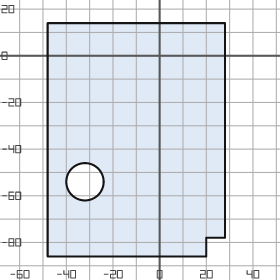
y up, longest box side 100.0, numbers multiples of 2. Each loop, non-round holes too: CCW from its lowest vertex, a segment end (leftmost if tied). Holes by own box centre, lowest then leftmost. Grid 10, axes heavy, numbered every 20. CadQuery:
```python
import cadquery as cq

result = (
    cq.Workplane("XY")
    .moveTo(-48.0, -86.0)
    .lineTo(20.0, -86.0)
    .lineTo(20.0, -78.0)
    .lineTo(28.0, -78.0)
    .lineTo(28.0, 14.0)
    .lineTo(-48.0, 14.0)
    .close()
    .moveTo(-32.0, -54.0)
    .circle(8.0)
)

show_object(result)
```